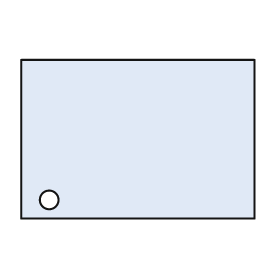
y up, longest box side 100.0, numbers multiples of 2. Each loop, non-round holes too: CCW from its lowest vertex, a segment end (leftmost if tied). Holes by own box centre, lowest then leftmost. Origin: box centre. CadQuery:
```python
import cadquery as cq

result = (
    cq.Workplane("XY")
    .moveTo(-50.0, -34.0)
    .lineTo(50.0, -34.0)
    .lineTo(50.0, 34.0)
    .lineTo(-50.0, 34.0)
    .close()
    .moveTo(-38.0, -26.0)
    .circle(4.0)
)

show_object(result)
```